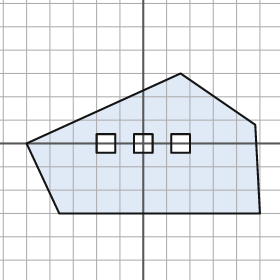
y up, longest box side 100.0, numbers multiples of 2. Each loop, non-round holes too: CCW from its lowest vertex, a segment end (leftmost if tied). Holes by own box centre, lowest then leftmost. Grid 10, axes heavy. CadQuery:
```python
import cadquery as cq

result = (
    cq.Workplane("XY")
    .moveTo(-36.0, -30.0)
    .lineTo(50.0, -30.0)
    .lineTo(48.0, 8.0)
    .lineTo(16.0, 30.0)
    .lineTo(-50.0, 0.0)
    .close()
    .moveTo(-20.0, -4.0)
    .lineTo(-12.0, -4.0)
    .lineTo(-12.0, 4.0)
    .lineTo(-20.0, 4.0)
    .close()
    .moveTo(-4.0, -4.0)
    .lineTo(4.0, -4.0)
    .lineTo(4.0, 4.0)
    .lineTo(-4.0, 4.0)
    .close()
    .moveTo(12.0, -4.0)
    .lineTo(20.0, -4.0)
    .lineTo(20.0, 4.0)
    .lineTo(12.0, 4.0)
    .close()
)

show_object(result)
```